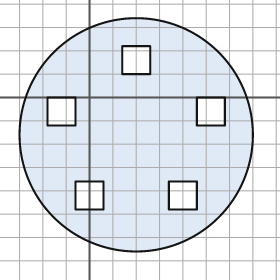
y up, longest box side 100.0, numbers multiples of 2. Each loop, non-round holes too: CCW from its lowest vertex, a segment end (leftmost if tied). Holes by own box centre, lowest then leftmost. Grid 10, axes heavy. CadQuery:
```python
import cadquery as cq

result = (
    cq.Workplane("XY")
    .moveTo(20.0, -16.0)
    .circle(50.0)
    .moveTo(-6.0, -48.0)
    .lineTo(6.0, -48.0)
    .lineTo(6.0, -36.0)
    .lineTo(-6.0, -36.0)
    .close()
    .moveTo(34.0, -48.0)
    .lineTo(46.0, -48.0)
    .lineTo(46.0, -36.0)
    .lineTo(34.0, -36.0)
    .close()
    .moveTo(-18.0, -12.0)
    .lineTo(-6.0, -12.0)
    .lineTo(-6.0, 0.0)
    .lineTo(-18.0, 0.0)
    .close()
    .moveTo(46.0, -12.0)
    .lineTo(58.0, -12.0)
    .lineTo(58.0, 0.0)
    .lineTo(46.0, 0.0)
    .close()
    .moveTo(14.0, 10.0)
    .lineTo(26.0, 10.0)
    .lineTo(26.0, 22.0)
    .lineTo(14.0, 22.0)
    .close()
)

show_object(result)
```